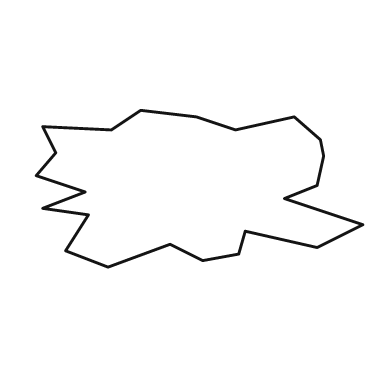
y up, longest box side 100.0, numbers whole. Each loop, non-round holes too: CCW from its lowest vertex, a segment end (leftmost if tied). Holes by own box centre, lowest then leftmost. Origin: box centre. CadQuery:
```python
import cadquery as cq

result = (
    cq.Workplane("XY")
    .moveTo(-28.0, -24.0)
    .lineTo(-9.0, -17.0)
    .lineTo(1.0, -22.0)
    .lineTo(12.0, -20.0)
    .lineTo(14.0, -13.0)
    .lineTo(36.0, -18.0)
    .lineTo(50.0, -11.0)
    .lineTo(26.0, -3.0)
    .lineTo(36.0, 1.0)
    .lineTo(38.0, 10.0)
    .lineTo(37.0, 15.0)
    .lineTo(29.0, 22.0)
    .lineTo(11.0, 18.0)
    .lineTo(-1.0, 22.0)
    .lineTo(-18.0, 24.0)
    .lineTo(-27.0, 18.0)
    .lineTo(-48.0, 19.0)
    .lineTo(-44.0, 11.0)
    .lineTo(-50.0, 4.0)
    .lineTo(-35.0, -1.0)
    .lineTo(-48.0, -6.0)
    .lineTo(-34.0, -8.0)
    .lineTo(-41.0, -19.0)
    .close()
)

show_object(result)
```